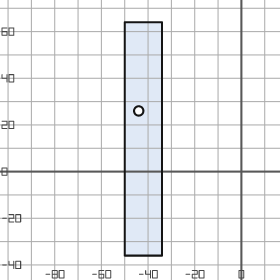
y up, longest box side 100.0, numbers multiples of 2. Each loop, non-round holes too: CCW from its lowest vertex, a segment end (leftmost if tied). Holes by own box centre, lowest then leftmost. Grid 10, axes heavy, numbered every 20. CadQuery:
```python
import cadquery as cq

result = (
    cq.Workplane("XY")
    .moveTo(-50.0, -36.0)
    .lineTo(-34.0, -36.0)
    .lineTo(-34.0, 64.0)
    .lineTo(-50.0, 64.0)
    .close()
    .moveTo(-44.0, 26.0)
    .circle(2.0)
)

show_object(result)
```